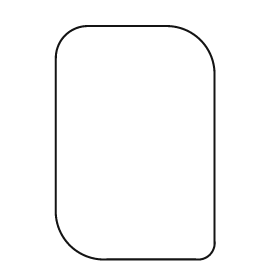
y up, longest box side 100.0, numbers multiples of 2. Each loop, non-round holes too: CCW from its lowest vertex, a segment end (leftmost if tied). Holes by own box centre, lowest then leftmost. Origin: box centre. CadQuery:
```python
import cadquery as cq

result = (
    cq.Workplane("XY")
    .moveTo(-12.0, -50.0)
    .lineTo(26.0, -50.0)
    .threePointArc((32.0, -48.0), (34.0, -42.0))
    .lineTo(34.0, 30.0)
    .threePointArc((28.0, 44.0), (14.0, 50.0))
    .lineTo(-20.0, 50.0)
    .threePointArc((-30.0, 46.0), (-34.0, 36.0))
    .lineTo(-34.0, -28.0)
    .threePointArc((-28.0, -44.0), (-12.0, -50.0))
    .close()
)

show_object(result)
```